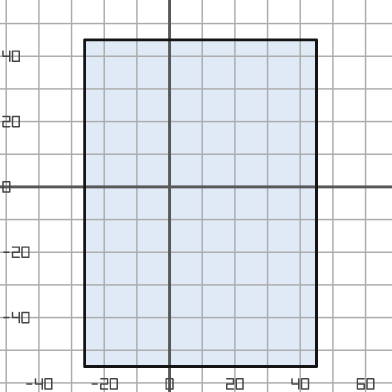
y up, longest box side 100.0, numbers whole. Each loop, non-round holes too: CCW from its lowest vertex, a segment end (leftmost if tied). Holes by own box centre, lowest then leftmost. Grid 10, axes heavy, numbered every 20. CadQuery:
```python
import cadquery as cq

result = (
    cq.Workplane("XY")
    .moveTo(-26.0, -55.0)
    .lineTo(45.0, -55.0)
    .lineTo(45.0, 45.0)
    .lineTo(-26.0, 45.0)
    .close()
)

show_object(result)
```